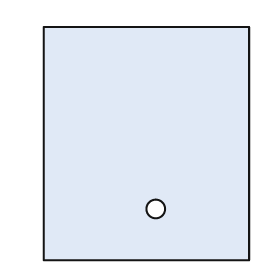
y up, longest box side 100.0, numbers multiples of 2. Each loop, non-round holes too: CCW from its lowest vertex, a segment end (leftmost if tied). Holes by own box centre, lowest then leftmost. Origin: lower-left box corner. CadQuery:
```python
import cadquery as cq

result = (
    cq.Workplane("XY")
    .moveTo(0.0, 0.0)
    .lineTo(88.0, 0.0)
    .lineTo(88.0, 100.0)
    .lineTo(0.0, 100.0)
    .close()
    .moveTo(48.0, 22.0)
    .circle(4.0)
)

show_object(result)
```